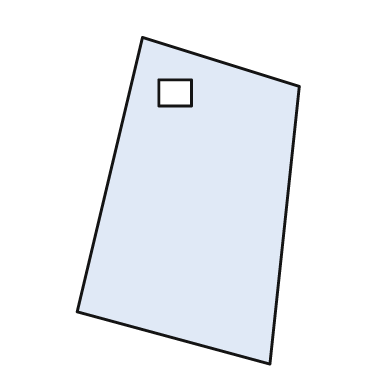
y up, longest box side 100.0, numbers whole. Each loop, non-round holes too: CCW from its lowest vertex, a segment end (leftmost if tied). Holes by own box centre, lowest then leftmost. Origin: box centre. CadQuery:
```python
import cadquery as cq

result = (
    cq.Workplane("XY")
    .moveTo(25.0, -50.0)
    .lineTo(34.0, 35.0)
    .lineTo(-14.0, 50.0)
    .lineTo(-34.0, -34.0)
    .close()
    .moveTo(-9.0, 29.0)
    .lineTo(1.0, 29.0)
    .lineTo(1.0, 37.0)
    .lineTo(-9.0, 37.0)
    .close()
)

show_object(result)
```